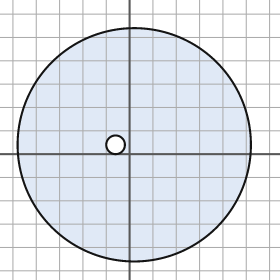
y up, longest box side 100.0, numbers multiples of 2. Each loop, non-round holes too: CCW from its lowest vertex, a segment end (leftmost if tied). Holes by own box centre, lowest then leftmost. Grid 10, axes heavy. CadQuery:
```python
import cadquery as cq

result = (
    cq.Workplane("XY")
    .moveTo(2.0, 4.0)
    .circle(50.0)
    .moveTo(-6.0, 4.0)
    .circle(4.0)
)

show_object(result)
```